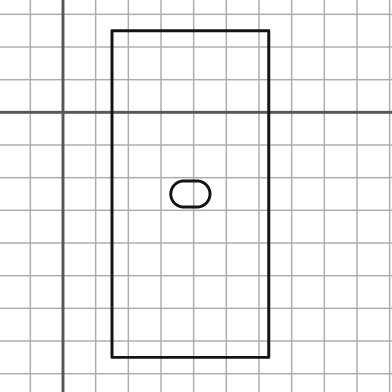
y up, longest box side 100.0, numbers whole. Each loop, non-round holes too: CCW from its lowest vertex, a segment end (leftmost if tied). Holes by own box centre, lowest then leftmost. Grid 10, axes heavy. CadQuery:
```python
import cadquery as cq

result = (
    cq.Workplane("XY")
    .moveTo(15.0, -75.0)
    .lineTo(63.0, -75.0)
    .lineTo(63.0, 25.0)
    .lineTo(15.0, 25.0)
    .close()
    .moveTo(37.0, -29.0)
    .lineTo(41.0, -29.0)
    .threePointArc((45.0, -25.0), (41.0, -21.0))
    .lineTo(37.0, -21.0)
    .threePointArc((33.0, -25.0), (37.0, -29.0))
    .close()
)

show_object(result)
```